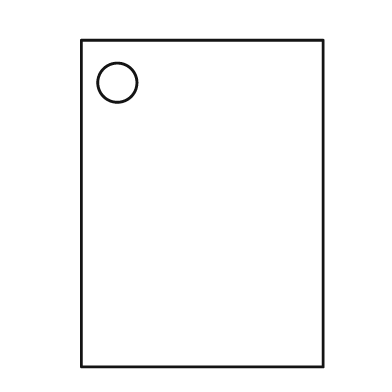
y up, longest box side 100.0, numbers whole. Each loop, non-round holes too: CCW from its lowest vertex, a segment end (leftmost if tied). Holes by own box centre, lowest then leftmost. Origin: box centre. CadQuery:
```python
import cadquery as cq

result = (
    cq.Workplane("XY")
    .moveTo(-37.0, -50.0)
    .lineTo(37.0, -50.0)
    .lineTo(37.0, 50.0)
    .lineTo(-37.0, 50.0)
    .close()
    .moveTo(-26.0, 37.0)
    .circle(6.0)
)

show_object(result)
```